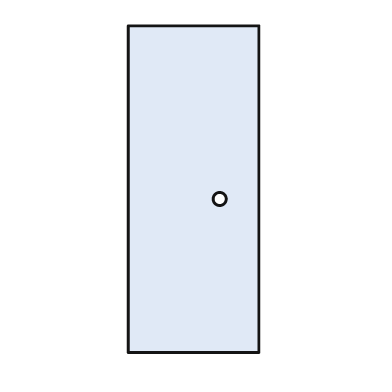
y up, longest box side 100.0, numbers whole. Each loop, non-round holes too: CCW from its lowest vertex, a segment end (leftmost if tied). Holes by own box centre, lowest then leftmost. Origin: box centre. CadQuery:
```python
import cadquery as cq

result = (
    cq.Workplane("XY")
    .moveTo(-20.0, -50.0)
    .lineTo(20.0, -50.0)
    .lineTo(20.0, 50.0)
    .lineTo(-20.0, 50.0)
    .close()
    .moveTo(8.0, -3.0)
    .circle(2.0)
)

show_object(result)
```